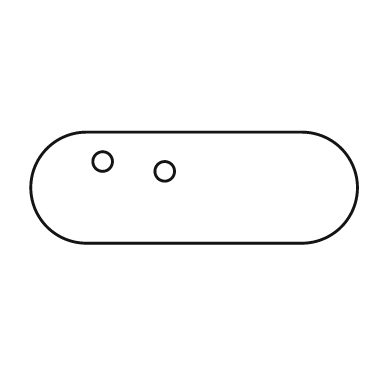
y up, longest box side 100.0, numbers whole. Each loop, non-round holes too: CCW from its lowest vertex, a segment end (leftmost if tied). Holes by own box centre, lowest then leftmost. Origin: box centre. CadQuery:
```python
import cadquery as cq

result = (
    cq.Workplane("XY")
    .moveTo(-33.0, -17.0)
    .lineTo(33.0, -17.0)
    .threePointArc((50.0, 0.0), (33.0, 17.0))
    .lineTo(-33.0, 17.0)
    .threePointArc((-50.0, 0.0), (-33.0, -17.0))
    .close()
    .moveTo(-9.0, 5.0)
    .circle(3.0)
    .moveTo(-28.0, 8.0)
    .circle(3.0)
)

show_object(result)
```